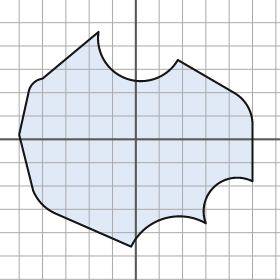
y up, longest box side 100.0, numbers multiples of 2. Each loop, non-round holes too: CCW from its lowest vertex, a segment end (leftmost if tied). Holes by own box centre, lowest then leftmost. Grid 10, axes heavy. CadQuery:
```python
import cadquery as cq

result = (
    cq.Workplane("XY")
    .moveTo(-2.0, -46.0)
    .threePointArc((12.0, -34.0), (30.0, -36.0))
    .threePointArc((34.0, -20.0), (50.0, -18.0))
    .lineTo(50.0, 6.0)
    .threePointArc((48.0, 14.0), (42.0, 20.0))
    .lineTo(18.0, 34.0)
    .threePointArc((-4.0, 26.0), (-16.0, 46.0))
    .lineTo(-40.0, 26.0)
    .threePointArc((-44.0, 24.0), (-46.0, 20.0))
    .lineTo(-50.0, 2.0)
    .lineTo(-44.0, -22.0)
    .threePointArc((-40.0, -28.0), (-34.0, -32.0))
    .close()
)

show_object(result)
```